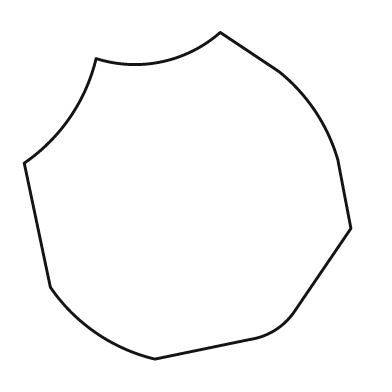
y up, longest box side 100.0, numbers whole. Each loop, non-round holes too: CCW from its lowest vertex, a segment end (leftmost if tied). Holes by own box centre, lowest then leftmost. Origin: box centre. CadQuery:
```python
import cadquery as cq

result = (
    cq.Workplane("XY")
    .moveTo(-10.0, -50.0)
    .lineTo(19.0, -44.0)
    .threePointArc((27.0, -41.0), (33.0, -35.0))
    .lineTo(50.0, -10.0)
    .lineTo(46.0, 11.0)
    .threePointArc((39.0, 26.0), (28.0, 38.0))
    .lineTo(10.0, 50.0)
    .threePointArc((-8.0, 41.0), (-28.0, 42.0))
    .threePointArc((-36.0, 24.0), (-50.0, 10.0))
    .lineTo(-42.0, -28.0)
    .threePointArc((-28.0, -42.0), (-10.0, -50.0))
    .close()
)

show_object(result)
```